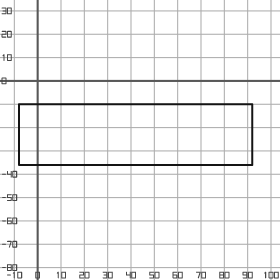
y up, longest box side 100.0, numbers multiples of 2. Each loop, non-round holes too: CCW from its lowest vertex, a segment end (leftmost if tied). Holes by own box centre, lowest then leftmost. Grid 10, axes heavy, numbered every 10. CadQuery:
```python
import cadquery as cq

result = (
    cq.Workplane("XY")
    .moveTo(-8.0, -36.0)
    .lineTo(92.0, -36.0)
    .lineTo(92.0, -10.0)
    .lineTo(-8.0, -10.0)
    .close()
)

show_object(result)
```